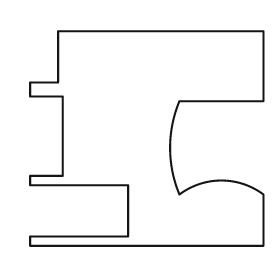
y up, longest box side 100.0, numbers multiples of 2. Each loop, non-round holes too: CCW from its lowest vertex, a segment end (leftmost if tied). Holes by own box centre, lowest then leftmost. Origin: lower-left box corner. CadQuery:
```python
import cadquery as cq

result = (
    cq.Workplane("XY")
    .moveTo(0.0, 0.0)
    .lineTo(100.0, 0.0)
    .lineTo(100.0, 22.0)
    .threePointArc((82.0, 28.0), (64.0, 22.0))
    .threePointArc((60.0, 42.0), (64.0, 62.0))
    .lineTo(100.0, 62.0)
    .lineTo(100.0, 92.0)
    .lineTo(12.0, 92.0)
    .lineTo(12.0, 70.0)
    .lineTo(0.0, 70.0)
    .lineTo(0.0, 64.0)
    .lineTo(14.0, 64.0)
    .lineTo(14.0, 30.0)
    .lineTo(0.0, 30.0)
    .lineTo(0.0, 26.0)
    .lineTo(42.0, 26.0)
    .lineTo(42.0, 4.0)
    .lineTo(0.0, 4.0)
    .close()
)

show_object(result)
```